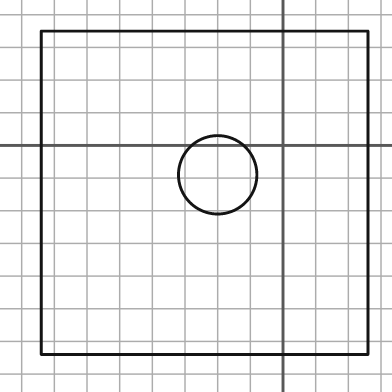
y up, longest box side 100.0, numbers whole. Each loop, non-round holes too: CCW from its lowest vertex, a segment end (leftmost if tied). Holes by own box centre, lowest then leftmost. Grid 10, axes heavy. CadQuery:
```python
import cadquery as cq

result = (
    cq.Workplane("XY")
    .moveTo(-74.0, -64.0)
    .lineTo(26.0, -64.0)
    .lineTo(26.0, 35.0)
    .lineTo(-74.0, 35.0)
    .close()
    .moveTo(-20.0, -9.0)
    .circle(12.0)
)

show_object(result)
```